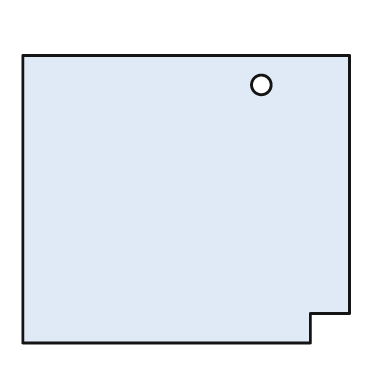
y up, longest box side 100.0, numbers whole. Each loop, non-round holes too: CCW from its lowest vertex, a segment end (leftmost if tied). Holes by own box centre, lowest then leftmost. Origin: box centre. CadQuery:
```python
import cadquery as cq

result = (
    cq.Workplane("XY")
    .moveTo(-50.0, -44.0)
    .lineTo(38.0, -44.0)
    .lineTo(38.0, -35.0)
    .lineTo(50.0, -35.0)
    .lineTo(50.0, 44.0)
    .lineTo(-50.0, 44.0)
    .close()
    .moveTo(23.0, 35.0)
    .circle(3.0)
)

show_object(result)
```